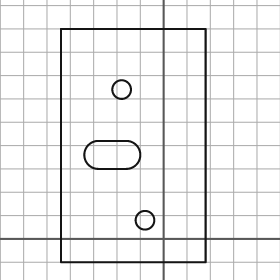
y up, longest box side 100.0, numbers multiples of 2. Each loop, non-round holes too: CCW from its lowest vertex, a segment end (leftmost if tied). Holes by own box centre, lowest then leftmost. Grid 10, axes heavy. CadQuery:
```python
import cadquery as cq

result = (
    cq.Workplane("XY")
    .moveTo(-44.0, -10.0)
    .lineTo(18.0, -10.0)
    .lineTo(18.0, 90.0)
    .lineTo(-44.0, 90.0)
    .close()
    .moveTo(-8.0, 8.0)
    .circle(4.0)
    .moveTo(-28.0, 30.0)
    .lineTo(-16.0, 30.0)
    .threePointArc((-10.0, 36.0), (-16.0, 42.0))
    .lineTo(-28.0, 42.0)
    .threePointArc((-34.0, 36.0), (-28.0, 30.0))
    .close()
    .moveTo(-18.0, 64.0)
    .circle(4.0)
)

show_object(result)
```